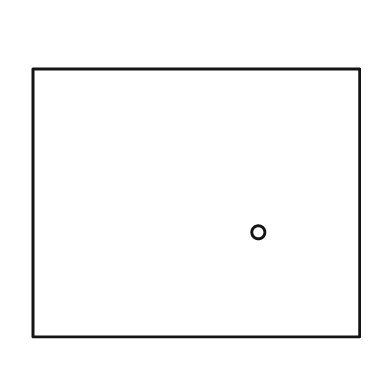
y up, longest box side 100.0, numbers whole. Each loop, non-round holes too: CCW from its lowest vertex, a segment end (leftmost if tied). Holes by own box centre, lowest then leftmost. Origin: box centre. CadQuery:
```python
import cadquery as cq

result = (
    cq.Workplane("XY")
    .moveTo(-50.0, -41.0)
    .lineTo(50.0, -41.0)
    .lineTo(50.0, 41.0)
    .lineTo(-50.0, 41.0)
    .close()
    .moveTo(19.0, -9.0)
    .circle(2.0)
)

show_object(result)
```